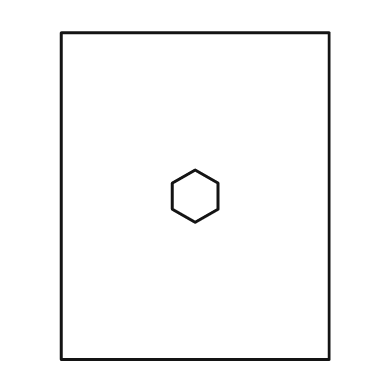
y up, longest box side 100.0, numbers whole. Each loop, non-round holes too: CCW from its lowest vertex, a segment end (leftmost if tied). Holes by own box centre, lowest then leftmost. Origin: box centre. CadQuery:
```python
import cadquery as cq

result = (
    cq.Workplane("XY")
    .moveTo(-41.0, -50.0)
    .lineTo(41.0, -50.0)
    .lineTo(41.0, 50.0)
    .lineTo(-41.0, 50.0)
    .close()
    .moveTo(0.0, -8.0)
    .lineTo(7.0, -4.0)
    .lineTo(7.0, 4.0)
    .lineTo(0.0, 8.0)
    .lineTo(-7.0, 4.0)
    .lineTo(-7.0, -4.0)
    .close()
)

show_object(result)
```